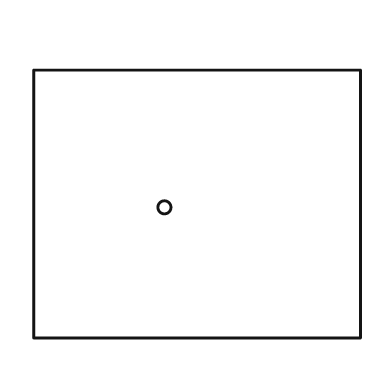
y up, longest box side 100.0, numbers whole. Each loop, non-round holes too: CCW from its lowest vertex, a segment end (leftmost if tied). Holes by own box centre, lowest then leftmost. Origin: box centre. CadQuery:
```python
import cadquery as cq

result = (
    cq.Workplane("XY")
    .moveTo(-50.0, -41.0)
    .lineTo(50.0, -41.0)
    .lineTo(50.0, 41.0)
    .lineTo(-50.0, 41.0)
    .close()
    .moveTo(-10.0, -1.0)
    .circle(2.0)
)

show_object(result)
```